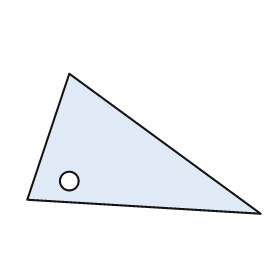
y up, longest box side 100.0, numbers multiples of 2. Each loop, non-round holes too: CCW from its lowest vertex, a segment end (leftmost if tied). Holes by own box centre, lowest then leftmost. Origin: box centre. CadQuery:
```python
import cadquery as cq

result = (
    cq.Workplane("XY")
    .moveTo(50.0, -30.0)
    .lineTo(-32.0, 30.0)
    .lineTo(-50.0, -24.0)
    .close()
    .moveTo(-32.0, -16.0)
    .circle(4.0)
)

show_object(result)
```